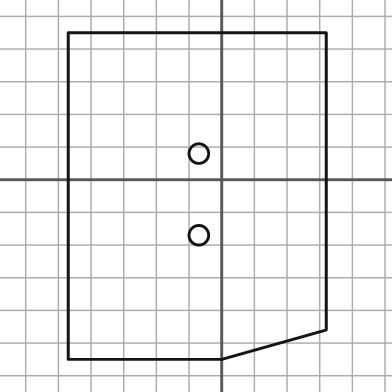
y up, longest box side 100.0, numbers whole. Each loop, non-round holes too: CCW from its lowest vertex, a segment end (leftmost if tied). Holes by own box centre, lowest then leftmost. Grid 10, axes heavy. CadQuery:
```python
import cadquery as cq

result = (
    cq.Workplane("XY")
    .moveTo(-47.0, -55.0)
    .lineTo(0.0, -55.0)
    .lineTo(32.0, -46.0)
    .lineTo(32.0, 45.0)
    .lineTo(-47.0, 45.0)
    .close()
    .moveTo(-7.0, -17.0)
    .circle(3.0)
    .moveTo(-7.0, 8.0)
    .circle(3.0)
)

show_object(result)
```